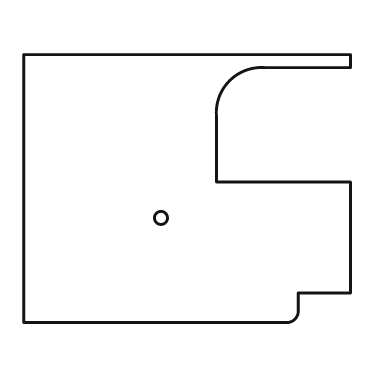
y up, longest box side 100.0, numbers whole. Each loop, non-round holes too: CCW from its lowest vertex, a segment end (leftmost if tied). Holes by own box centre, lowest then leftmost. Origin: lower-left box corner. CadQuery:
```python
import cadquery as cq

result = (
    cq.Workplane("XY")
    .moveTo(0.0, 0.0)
    .lineTo(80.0, 0.0)
    .threePointArc((83.0, 1.0), (84.0, 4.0))
    .lineTo(84.0, 9.0)
    .lineTo(100.0, 9.0)
    .lineTo(100.0, 43.0)
    .lineTo(59.0, 43.0)
    .lineTo(59.0, 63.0)
    .threePointArc((63.0, 74.0), (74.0, 78.0))
    .lineTo(100.0, 78.0)
    .lineTo(100.0, 82.0)
    .lineTo(0.0, 82.0)
    .close()
    .moveTo(42.0, 32.0)
    .circle(2.0)
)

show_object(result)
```